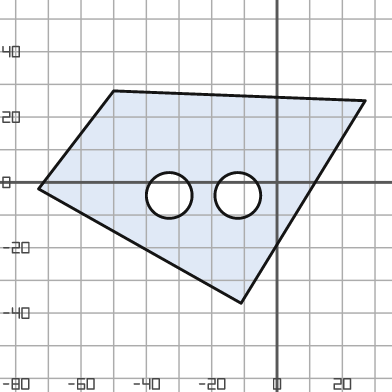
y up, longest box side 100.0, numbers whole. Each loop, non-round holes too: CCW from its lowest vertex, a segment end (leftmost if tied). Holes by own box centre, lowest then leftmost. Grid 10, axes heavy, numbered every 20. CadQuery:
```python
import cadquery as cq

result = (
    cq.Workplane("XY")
    .moveTo(-11.0, -37.0)
    .lineTo(27.0, 25.0)
    .lineTo(-50.0, 28.0)
    .lineTo(-73.0, -2.0)
    .close()
    .moveTo(-33.0, -4.0)
    .circle(7.0)
    .moveTo(-12.0, -4.0)
    .circle(7.0)
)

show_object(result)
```